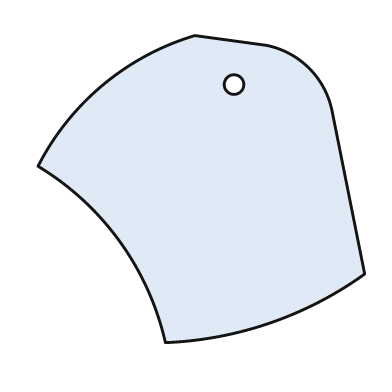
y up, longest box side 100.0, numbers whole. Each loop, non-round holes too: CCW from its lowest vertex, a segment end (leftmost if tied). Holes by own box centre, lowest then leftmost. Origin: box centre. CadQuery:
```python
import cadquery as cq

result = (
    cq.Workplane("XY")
    .moveTo(-11.0, -47.0)
    .threePointArc((21.0, -41.0), (50.0, -26.0))
    .lineTo(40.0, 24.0)
    .threePointArc((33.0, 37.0), (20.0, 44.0))
    .lineTo(-2.0, 47.0)
    .threePointArc((-30.0, 32.0), (-50.0, 7.0))
    .threePointArc((-25.0, -16.0), (-11.0, -47.0))
    .close()
    .moveTo(10.0, 32.0)
    .circle(3.0)
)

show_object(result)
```